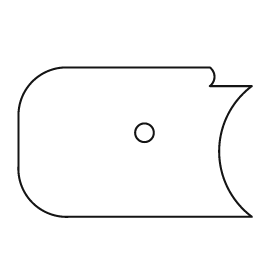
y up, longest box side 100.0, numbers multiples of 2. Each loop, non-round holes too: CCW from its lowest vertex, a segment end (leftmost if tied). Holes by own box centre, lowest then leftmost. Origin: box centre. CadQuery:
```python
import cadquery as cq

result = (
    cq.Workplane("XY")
    .moveTo(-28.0, -32.0)
    .lineTo(50.0, -32.0)
    .threePointArc((36.0, -4.0), (50.0, 24.0))
    .lineTo(32.0, 24.0)
    .threePointArc((34.0, 28.0), (32.0, 32.0))
    .lineTo(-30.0, 32.0)
    .threePointArc((-44.0, 26.0), (-50.0, 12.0))
    .lineTo(-50.0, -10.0)
    .threePointArc((-44.0, -26.0), (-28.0, -32.0))
    .close()
    .moveTo(4.0, 4.0)
    .circle(4.0)
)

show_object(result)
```